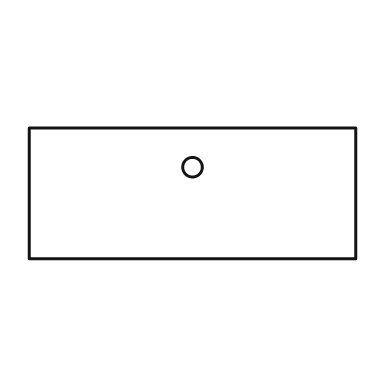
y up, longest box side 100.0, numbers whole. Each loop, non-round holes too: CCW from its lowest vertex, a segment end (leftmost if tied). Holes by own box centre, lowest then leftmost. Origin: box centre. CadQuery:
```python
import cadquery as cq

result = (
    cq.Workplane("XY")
    .moveTo(-50.0, -20.0)
    .lineTo(50.0, -20.0)
    .lineTo(50.0, 20.0)
    .lineTo(-50.0, 20.0)
    .close()
    .moveTo(0.0, 8.0)
    .circle(3.0)
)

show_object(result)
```